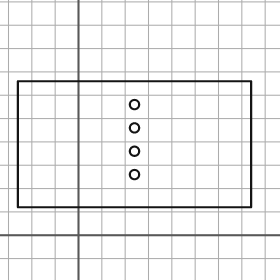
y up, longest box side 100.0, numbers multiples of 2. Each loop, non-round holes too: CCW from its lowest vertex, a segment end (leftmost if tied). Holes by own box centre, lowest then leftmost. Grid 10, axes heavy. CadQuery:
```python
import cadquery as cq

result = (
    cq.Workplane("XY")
    .moveTo(-26.0, 12.0)
    .lineTo(74.0, 12.0)
    .lineTo(74.0, 66.0)
    .lineTo(-26.0, 66.0)
    .close()
    .moveTo(24.0, 26.0)
    .circle(2.0)
    .moveTo(24.0, 36.0)
    .circle(2.0)
    .moveTo(24.0, 46.0)
    .circle(2.0)
    .moveTo(24.0, 56.0)
    .circle(2.0)
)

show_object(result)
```